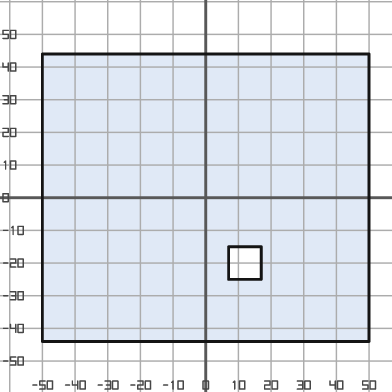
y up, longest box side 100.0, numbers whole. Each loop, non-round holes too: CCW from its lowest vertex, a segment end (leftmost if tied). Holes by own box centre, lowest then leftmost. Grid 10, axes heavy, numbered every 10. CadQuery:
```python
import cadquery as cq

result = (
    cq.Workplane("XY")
    .moveTo(-50.0, -44.0)
    .lineTo(50.0, -44.0)
    .lineTo(50.0, 44.0)
    .lineTo(-50.0, 44.0)
    .close()
    .moveTo(7.0, -25.0)
    .lineTo(17.0, -25.0)
    .lineTo(17.0, -15.0)
    .lineTo(7.0, -15.0)
    .close()
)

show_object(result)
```